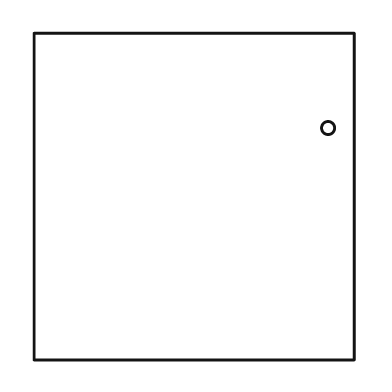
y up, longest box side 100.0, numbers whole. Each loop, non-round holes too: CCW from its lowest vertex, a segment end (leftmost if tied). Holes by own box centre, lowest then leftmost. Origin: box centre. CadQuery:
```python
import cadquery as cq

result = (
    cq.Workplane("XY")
    .moveTo(-49.0, -50.0)
    .lineTo(49.0, -50.0)
    .lineTo(49.0, 50.0)
    .lineTo(-49.0, 50.0)
    .close()
    .moveTo(41.0, 21.0)
    .circle(2.0)
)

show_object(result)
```